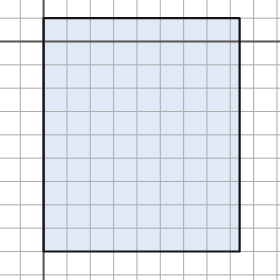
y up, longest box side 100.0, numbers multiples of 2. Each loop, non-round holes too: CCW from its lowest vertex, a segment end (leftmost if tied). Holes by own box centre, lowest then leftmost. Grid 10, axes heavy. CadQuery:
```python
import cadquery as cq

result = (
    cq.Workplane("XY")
    .moveTo(0.0, -90.0)
    .lineTo(84.0, -90.0)
    .lineTo(84.0, 10.0)
    .lineTo(0.0, 10.0)
    .close()
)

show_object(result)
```